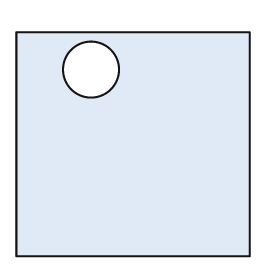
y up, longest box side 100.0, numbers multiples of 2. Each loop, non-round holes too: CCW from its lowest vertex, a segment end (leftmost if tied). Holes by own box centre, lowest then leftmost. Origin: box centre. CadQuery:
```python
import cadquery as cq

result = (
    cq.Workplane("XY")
    .moveTo(-50.0, -48.0)
    .lineTo(50.0, -48.0)
    .lineTo(50.0, 48.0)
    .lineTo(-50.0, 48.0)
    .close()
    .moveTo(-18.0, 32.0)
    .circle(12.0)
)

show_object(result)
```